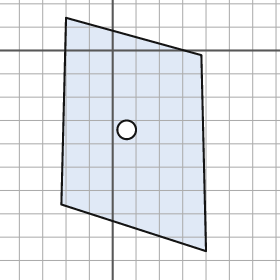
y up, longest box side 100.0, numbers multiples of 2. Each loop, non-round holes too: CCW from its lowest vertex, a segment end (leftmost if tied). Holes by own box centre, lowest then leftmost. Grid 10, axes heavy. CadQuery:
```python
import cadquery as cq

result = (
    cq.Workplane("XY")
    .moveTo(40.0, -86.0)
    .lineTo(38.0, -2.0)
    .lineTo(-20.0, 14.0)
    .lineTo(-22.0, -66.0)
    .close()
    .moveTo(6.0, -34.0)
    .circle(4.0)
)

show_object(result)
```